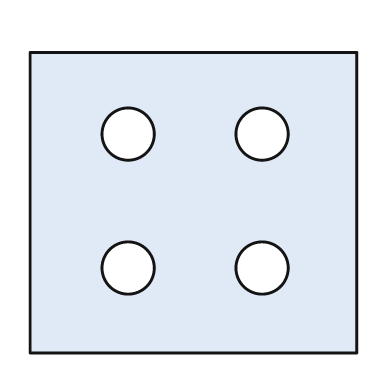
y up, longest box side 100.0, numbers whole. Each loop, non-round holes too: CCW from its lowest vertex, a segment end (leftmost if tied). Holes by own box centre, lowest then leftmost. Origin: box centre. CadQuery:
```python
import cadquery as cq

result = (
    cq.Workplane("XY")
    .moveTo(-50.0, -46.0)
    .lineTo(50.0, -46.0)
    .lineTo(50.0, 46.0)
    .lineTo(-50.0, 46.0)
    .close()
    .moveTo(-20.0, -20.0)
    .circle(8.0)
    .moveTo(21.0, -20.0)
    .circle(8.0)
    .moveTo(-20.0, 21.0)
    .circle(8.0)
    .moveTo(21.0, 21.0)
    .circle(8.0)
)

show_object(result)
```